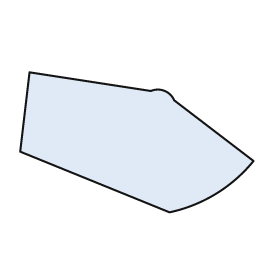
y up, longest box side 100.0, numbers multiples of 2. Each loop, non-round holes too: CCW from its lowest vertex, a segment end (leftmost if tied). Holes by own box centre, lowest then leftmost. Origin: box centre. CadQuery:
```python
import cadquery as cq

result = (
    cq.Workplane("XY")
    .moveTo(14.0, -30.0)
    .threePointArc((34.0, -22.0), (50.0, -8.0))
    .lineTo(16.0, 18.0)
    .threePointArc((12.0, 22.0), (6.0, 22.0))
    .lineTo(-46.0, 30.0)
    .lineTo(-50.0, -4.0)
    .close()
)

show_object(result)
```